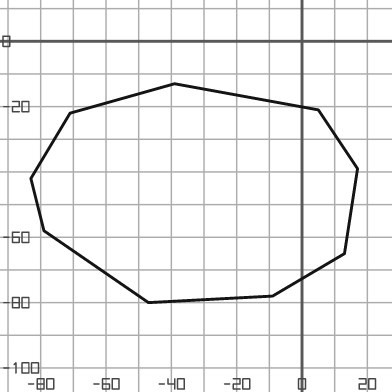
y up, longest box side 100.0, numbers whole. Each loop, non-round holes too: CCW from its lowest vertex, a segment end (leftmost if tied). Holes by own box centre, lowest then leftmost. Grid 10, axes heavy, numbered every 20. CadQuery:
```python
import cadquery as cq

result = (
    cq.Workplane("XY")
    .moveTo(-47.0, -80.0)
    .lineTo(-9.0, -78.0)
    .lineTo(13.0, -65.0)
    .lineTo(17.0, -39.0)
    .lineTo(5.0, -21.0)
    .lineTo(-39.0, -13.0)
    .lineTo(-71.0, -22.0)
    .lineTo(-83.0, -42.0)
    .lineTo(-79.0, -58.0)
    .close()
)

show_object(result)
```